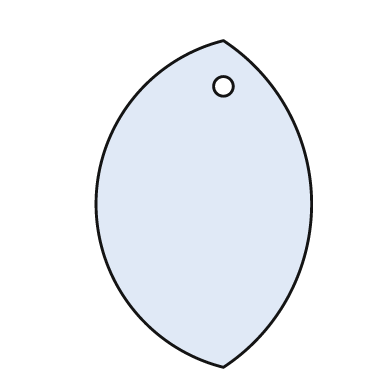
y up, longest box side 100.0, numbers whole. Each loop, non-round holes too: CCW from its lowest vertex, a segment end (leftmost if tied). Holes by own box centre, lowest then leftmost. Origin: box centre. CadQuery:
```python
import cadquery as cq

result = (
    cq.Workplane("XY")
    .moveTo(6.0, -50.0)
    .threePointArc((33.0, 0.0), (6.0, 50.0))
    .threePointArc((-33.0, 0.0), (6.0, -50.0))
    .close()
    .moveTo(6.0, 36.0)
    .circle(3.0)
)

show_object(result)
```